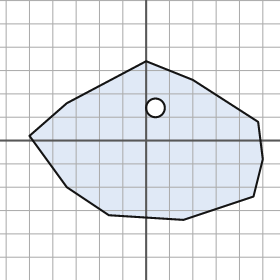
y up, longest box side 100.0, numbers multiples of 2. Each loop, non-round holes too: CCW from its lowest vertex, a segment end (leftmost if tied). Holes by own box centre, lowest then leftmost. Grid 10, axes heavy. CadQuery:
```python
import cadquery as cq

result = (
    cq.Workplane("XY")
    .moveTo(16.0, -34.0)
    .lineTo(46.0, -24.0)
    .lineTo(50.0, -8.0)
    .lineTo(48.0, 8.0)
    .lineTo(20.0, 26.0)
    .lineTo(0.0, 34.0)
    .lineTo(-34.0, 16.0)
    .lineTo(-50.0, 2.0)
    .lineTo(-34.0, -20.0)
    .lineTo(-16.0, -32.0)
    .close()
    .moveTo(4.0, 14.0)
    .circle(4.0)
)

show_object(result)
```